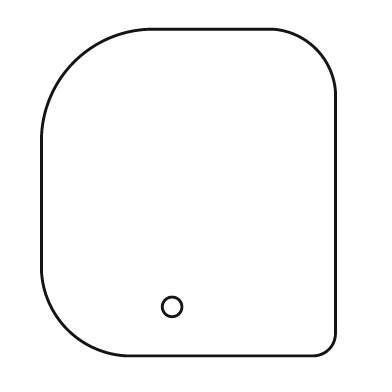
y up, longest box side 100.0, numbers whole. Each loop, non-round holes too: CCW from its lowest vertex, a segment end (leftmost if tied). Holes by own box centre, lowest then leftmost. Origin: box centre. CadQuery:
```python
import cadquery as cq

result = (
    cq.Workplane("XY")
    .moveTo(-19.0, -50.0)
    .lineTo(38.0, -50.0)
    .threePointArc((43.0, -48.0), (45.0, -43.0))
    .lineTo(45.0, 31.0)
    .threePointArc((39.0, 44.0), (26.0, 50.0))
    .lineTo(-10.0, 50.0)
    .threePointArc((-35.0, 40.0), (-45.0, 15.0))
    .lineTo(-45.0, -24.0)
    .threePointArc((-37.0, -42.0), (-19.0, -50.0))
    .close()
    .moveTo(-5.0, -35.0)
    .circle(3.0)
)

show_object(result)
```